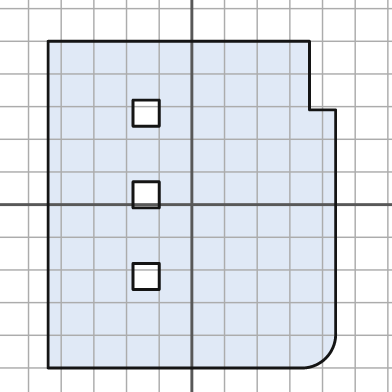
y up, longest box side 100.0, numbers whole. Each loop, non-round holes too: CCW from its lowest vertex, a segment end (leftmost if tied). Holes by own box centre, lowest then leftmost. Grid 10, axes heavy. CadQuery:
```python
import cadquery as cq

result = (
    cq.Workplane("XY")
    .moveTo(-44.0, -50.0)
    .lineTo(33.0, -50.0)
    .threePointArc((41.0, -47.0), (44.0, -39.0))
    .lineTo(44.0, 29.0)
    .lineTo(36.0, 29.0)
    .lineTo(36.0, 50.0)
    .lineTo(-44.0, 50.0)
    .close()
    .moveTo(-18.0, -26.0)
    .lineTo(-10.0, -26.0)
    .lineTo(-10.0, -18.0)
    .lineTo(-18.0, -18.0)
    .close()
    .moveTo(-18.0, -1.0)
    .lineTo(-10.0, -1.0)
    .lineTo(-10.0, 7.0)
    .lineTo(-18.0, 7.0)
    .close()
    .moveTo(-18.0, 24.0)
    .lineTo(-10.0, 24.0)
    .lineTo(-10.0, 32.0)
    .lineTo(-18.0, 32.0)
    .close()
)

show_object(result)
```